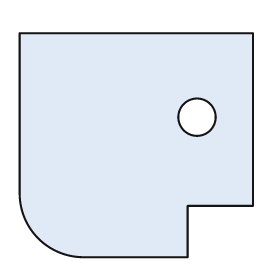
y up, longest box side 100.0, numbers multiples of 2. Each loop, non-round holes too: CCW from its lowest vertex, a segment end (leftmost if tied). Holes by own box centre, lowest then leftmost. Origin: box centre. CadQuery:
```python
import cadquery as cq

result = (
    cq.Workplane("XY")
    .moveTo(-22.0, -48.0)
    .lineTo(22.0, -48.0)
    .lineTo(22.0, -26.0)
    .lineTo(50.0, -26.0)
    .lineTo(50.0, 48.0)
    .lineTo(-50.0, 48.0)
    .lineTo(-50.0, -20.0)
    .threePointArc((-42.0, -40.0), (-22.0, -48.0))
    .close()
    .moveTo(26.0, 12.0)
    .circle(8.0)
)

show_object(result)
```